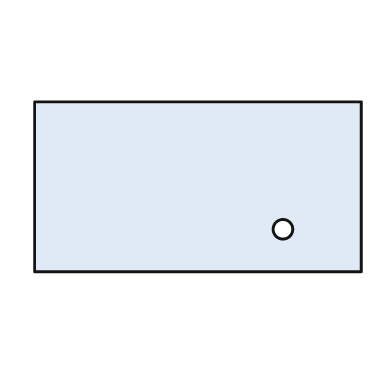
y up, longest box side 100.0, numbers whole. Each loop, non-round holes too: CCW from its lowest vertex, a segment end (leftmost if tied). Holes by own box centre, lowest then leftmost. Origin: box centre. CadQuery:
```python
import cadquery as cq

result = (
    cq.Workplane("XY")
    .moveTo(-50.0, -26.0)
    .lineTo(50.0, -26.0)
    .lineTo(50.0, 26.0)
    .lineTo(-50.0, 26.0)
    .close()
    .moveTo(26.0, -13.0)
    .circle(3.0)
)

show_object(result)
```